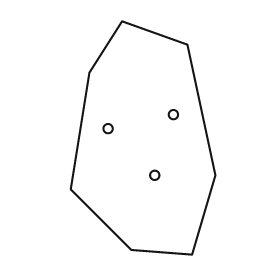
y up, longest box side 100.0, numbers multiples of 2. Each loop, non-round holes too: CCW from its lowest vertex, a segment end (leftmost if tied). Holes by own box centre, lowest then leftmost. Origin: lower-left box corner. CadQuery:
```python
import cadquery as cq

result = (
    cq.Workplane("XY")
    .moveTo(52.0, 0.0)
    .lineTo(62.0, 34.0)
    .lineTo(50.0, 90.0)
    .lineTo(22.0, 100.0)
    .lineTo(8.0, 78.0)
    .lineTo(0.0, 28.0)
    .lineTo(26.0, 2.0)
    .close()
    .moveTo(36.0, 34.0)
    .circle(2.0)
    .moveTo(16.0, 54.0)
    .circle(2.0)
    .moveTo(44.0, 60.0)
    .circle(2.0)
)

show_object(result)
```